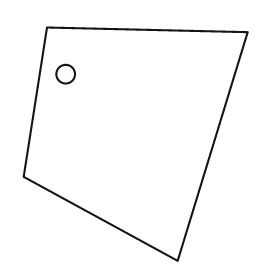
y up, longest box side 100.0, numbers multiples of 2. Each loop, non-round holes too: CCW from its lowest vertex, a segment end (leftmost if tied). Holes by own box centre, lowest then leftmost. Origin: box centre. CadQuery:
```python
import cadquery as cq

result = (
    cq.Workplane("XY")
    .moveTo(18.0, -50.0)
    .lineTo(48.0, 48.0)
    .lineTo(-38.0, 50.0)
    .lineTo(-48.0, -14.0)
    .close()
    .moveTo(-30.0, 30.0)
    .circle(4.0)
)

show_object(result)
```